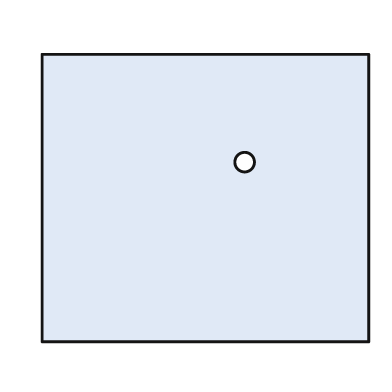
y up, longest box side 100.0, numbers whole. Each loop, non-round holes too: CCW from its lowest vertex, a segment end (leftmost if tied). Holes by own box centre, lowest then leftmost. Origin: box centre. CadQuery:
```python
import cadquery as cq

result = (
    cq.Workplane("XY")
    .moveTo(-50.0, -44.0)
    .lineTo(50.0, -44.0)
    .lineTo(50.0, 44.0)
    .lineTo(-50.0, 44.0)
    .close()
    .moveTo(12.0, 11.0)
    .circle(3.0)
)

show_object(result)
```